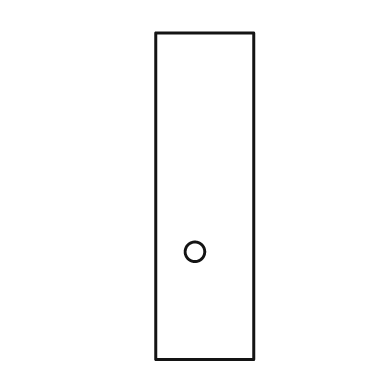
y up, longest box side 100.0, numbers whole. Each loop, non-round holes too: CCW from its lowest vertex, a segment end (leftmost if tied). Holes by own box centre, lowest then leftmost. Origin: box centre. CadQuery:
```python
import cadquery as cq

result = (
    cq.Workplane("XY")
    .moveTo(-15.0, -50.0)
    .lineTo(15.0, -50.0)
    .lineTo(15.0, 50.0)
    .lineTo(-15.0, 50.0)
    .close()
    .moveTo(-3.0, -17.0)
    .circle(3.0)
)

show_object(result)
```